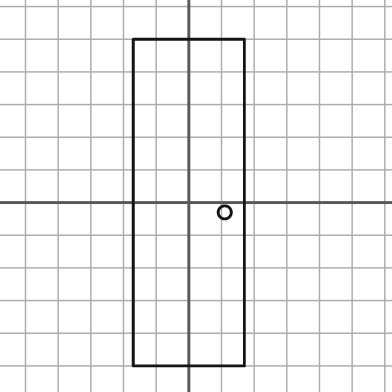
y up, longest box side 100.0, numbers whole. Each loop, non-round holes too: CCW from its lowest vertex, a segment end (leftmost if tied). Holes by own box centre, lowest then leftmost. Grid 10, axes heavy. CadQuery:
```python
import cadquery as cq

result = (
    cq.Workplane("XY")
    .moveTo(-17.0, -50.0)
    .lineTo(17.0, -50.0)
    .lineTo(17.0, 50.0)
    .lineTo(-17.0, 50.0)
    .close()
    .moveTo(11.0, -3.0)
    .circle(2.0)
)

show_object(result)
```